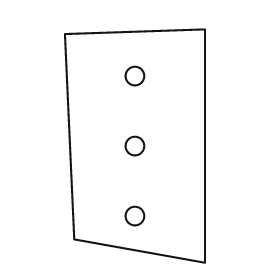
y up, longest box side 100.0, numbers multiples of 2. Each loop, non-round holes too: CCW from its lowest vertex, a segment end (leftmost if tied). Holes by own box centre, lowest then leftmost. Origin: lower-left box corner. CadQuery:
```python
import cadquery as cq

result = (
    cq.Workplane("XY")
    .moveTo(60.0, 0.0)
    .lineTo(60.0, 100.0)
    .lineTo(0.0, 98.0)
    .lineTo(4.0, 10.0)
    .close()
    .moveTo(30.0, 20.0)
    .circle(4.0)
    .moveTo(30.0, 50.0)
    .circle(4.0)
    .moveTo(30.0, 80.0)
    .circle(4.0)
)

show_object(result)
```